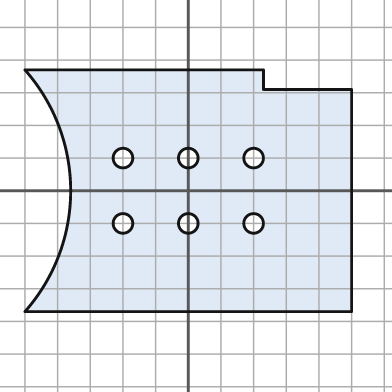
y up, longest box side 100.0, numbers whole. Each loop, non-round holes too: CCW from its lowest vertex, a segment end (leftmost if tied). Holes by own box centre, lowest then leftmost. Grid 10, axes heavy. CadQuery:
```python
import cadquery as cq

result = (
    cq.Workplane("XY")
    .moveTo(-50.0, -37.0)
    .lineTo(50.0, -37.0)
    .lineTo(50.0, 31.0)
    .lineTo(23.0, 31.0)
    .lineTo(23.0, 37.0)
    .lineTo(-50.0, 37.0)
    .threePointArc((-36.0, 0.0), (-50.0, -37.0))
    .close()
    .moveTo(-20.0, -10.0)
    .circle(3.0)
    .moveTo(0.0, -10.0)
    .circle(3.0)
    .moveTo(20.0, -10.0)
    .circle(3.0)
    .moveTo(-20.0, 10.0)
    .circle(3.0)
    .moveTo(0.0, 10.0)
    .circle(3.0)
    .moveTo(20.0, 10.0)
    .circle(3.0)
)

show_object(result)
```